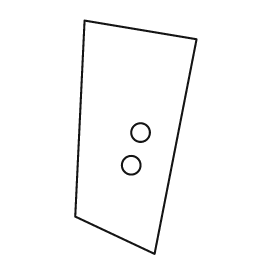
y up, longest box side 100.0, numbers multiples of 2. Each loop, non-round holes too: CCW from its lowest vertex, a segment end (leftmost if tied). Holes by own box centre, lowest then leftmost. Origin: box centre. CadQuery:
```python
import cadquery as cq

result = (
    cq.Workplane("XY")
    .moveTo(8.0, -50.0)
    .lineTo(26.0, 42.0)
    .lineTo(-22.0, 50.0)
    .lineTo(-26.0, -34.0)
    .close()
    .moveTo(-2.0, -12.0)
    .circle(4.0)
    .moveTo(2.0, 2.0)
    .circle(4.0)
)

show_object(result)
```